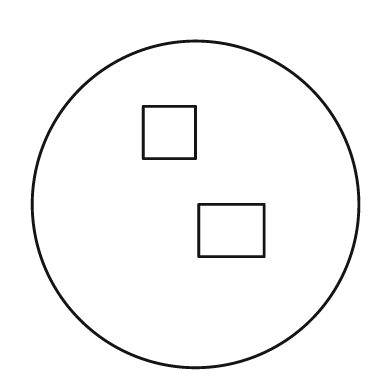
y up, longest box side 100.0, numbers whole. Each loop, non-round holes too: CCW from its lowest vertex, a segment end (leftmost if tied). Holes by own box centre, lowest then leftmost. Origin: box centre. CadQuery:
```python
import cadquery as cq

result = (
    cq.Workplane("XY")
    .moveTo(0.0, 0.0)
    .circle(50.0)
    .moveTo(1.0, -16.0)
    .lineTo(21.0, -16.0)
    .lineTo(21.0, 0.0)
    .lineTo(1.0, 0.0)
    .close()
    .moveTo(-16.0, 14.0)
    .lineTo(0.0, 14.0)
    .lineTo(0.0, 30.0)
    .lineTo(-16.0, 30.0)
    .close()
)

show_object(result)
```